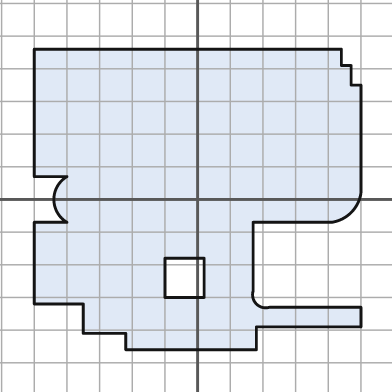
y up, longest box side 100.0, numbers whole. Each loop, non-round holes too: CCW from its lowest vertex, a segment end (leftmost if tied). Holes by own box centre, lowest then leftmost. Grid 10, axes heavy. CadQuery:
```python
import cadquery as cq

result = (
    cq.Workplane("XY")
    .moveTo(-22.0, -46.0)
    .lineTo(18.0, -46.0)
    .lineTo(18.0, -39.0)
    .lineTo(50.0, -39.0)
    .lineTo(50.0, -33.0)
    .lineTo(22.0, -33.0)
    .threePointArc((18.0, -32.0), (17.0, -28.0))
    .lineTo(17.0, -7.0)
    .lineTo(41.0, -7.0)
    .threePointArc((47.0, -4.0), (50.0, 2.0))
    .lineTo(50.0, 35.0)
    .lineTo(47.0, 35.0)
    .lineTo(47.0, 41.0)
    .lineTo(44.0, 41.0)
    .lineTo(44.0, 46.0)
    .lineTo(-50.0, 46.0)
    .lineTo(-50.0, 7.0)
    .lineTo(-40.0, 7.0)
    .threePointArc((-44.0, 0.0), (-40.0, -7.0))
    .lineTo(-50.0, -7.0)
    .lineTo(-50.0, -32.0)
    .lineTo(-35.0, -32.0)
    .lineTo(-35.0, -41.0)
    .lineTo(-22.0, -41.0)
    .close()
    .moveTo(-10.0, -30.0)
    .lineTo(2.0, -30.0)
    .lineTo(2.0, -18.0)
    .lineTo(-10.0, -18.0)
    .close()
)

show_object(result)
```